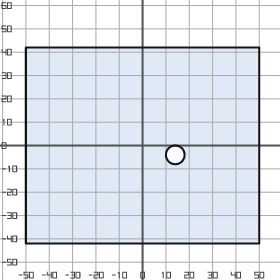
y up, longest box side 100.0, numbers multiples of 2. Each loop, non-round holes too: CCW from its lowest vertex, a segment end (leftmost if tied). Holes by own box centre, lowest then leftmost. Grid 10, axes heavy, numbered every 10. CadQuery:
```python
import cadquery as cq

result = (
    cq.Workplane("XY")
    .moveTo(-50.0, -42.0)
    .lineTo(50.0, -42.0)
    .lineTo(50.0, 42.0)
    .lineTo(-50.0, 42.0)
    .close()
    .moveTo(14.0, -4.0)
    .circle(4.0)
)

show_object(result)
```